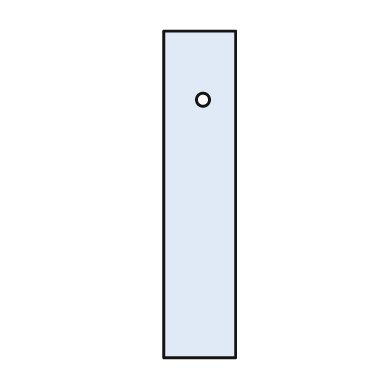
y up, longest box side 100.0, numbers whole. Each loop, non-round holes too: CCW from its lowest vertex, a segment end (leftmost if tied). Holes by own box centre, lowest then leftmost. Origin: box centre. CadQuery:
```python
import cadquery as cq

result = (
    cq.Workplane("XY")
    .moveTo(-11.0, -50.0)
    .lineTo(11.0, -50.0)
    .lineTo(11.0, 50.0)
    .lineTo(-11.0, 50.0)
    .close()
    .moveTo(1.0, 29.0)
    .circle(2.0)
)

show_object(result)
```